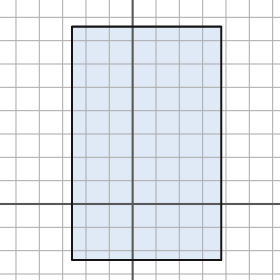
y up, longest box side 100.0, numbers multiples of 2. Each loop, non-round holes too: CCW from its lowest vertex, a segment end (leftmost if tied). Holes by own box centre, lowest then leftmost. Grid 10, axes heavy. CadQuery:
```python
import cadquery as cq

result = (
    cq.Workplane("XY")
    .moveTo(-26.0, -24.0)
    .lineTo(38.0, -24.0)
    .lineTo(38.0, 76.0)
    .lineTo(-26.0, 76.0)
    .close()
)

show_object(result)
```